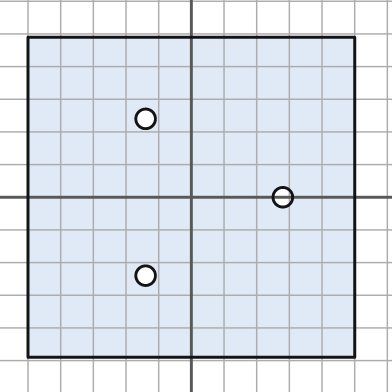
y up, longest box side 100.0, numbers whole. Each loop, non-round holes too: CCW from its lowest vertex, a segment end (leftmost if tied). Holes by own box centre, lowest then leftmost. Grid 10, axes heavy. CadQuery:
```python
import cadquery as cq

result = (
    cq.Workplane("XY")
    .moveTo(-50.0, -49.0)
    .lineTo(50.0, -49.0)
    .lineTo(50.0, 49.0)
    .lineTo(-50.0, 49.0)
    .close()
    .moveTo(-14.0, -24.0)
    .circle(3.0)
    .moveTo(28.0, 0.0)
    .circle(3.0)
    .moveTo(-14.0, 24.0)
    .circle(3.0)
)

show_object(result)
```